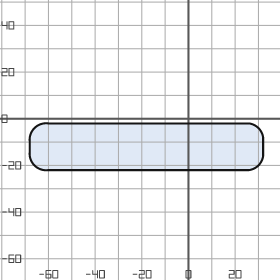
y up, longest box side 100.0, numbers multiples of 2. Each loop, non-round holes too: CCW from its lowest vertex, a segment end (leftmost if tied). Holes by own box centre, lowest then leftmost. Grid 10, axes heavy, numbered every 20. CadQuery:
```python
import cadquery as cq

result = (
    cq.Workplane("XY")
    .moveTo(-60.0, -22.0)
    .lineTo(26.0, -22.0)
    .threePointArc((30.0, -20.0), (32.0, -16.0))
    .lineTo(32.0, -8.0)
    .threePointArc((30.0, -4.0), (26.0, -2.0))
    .lineTo(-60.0, -2.0)
    .threePointArc((-66.0, -4.0), (-68.0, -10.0))
    .lineTo(-68.0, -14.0)
    .threePointArc((-66.0, -20.0), (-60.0, -22.0))
    .close()
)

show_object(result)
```